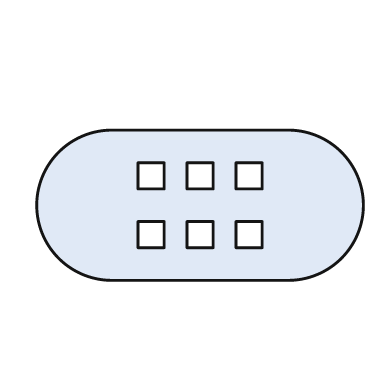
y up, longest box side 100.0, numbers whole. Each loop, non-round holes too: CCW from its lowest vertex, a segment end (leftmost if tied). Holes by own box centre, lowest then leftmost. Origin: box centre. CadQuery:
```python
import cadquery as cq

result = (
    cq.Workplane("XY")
    .moveTo(-27.0, -23.0)
    .lineTo(27.0, -23.0)
    .threePointArc((50.0, 0.0), (27.0, 23.0))
    .lineTo(-27.0, 23.0)
    .threePointArc((-50.0, 0.0), (-27.0, -23.0))
    .close()
    .moveTo(-19.0, -13.0)
    .lineTo(-11.0, -13.0)
    .lineTo(-11.0, -5.0)
    .lineTo(-19.0, -5.0)
    .close()
    .moveTo(-4.0, -13.0)
    .lineTo(4.0, -13.0)
    .lineTo(4.0, -5.0)
    .lineTo(-4.0, -5.0)
    .close()
    .moveTo(11.0, -13.0)
    .lineTo(19.0, -13.0)
    .lineTo(19.0, -5.0)
    .lineTo(11.0, -5.0)
    .close()
    .moveTo(-19.0, 5.0)
    .lineTo(-11.0, 5.0)
    .lineTo(-11.0, 13.0)
    .lineTo(-19.0, 13.0)
    .close()
    .moveTo(-4.0, 5.0)
    .lineTo(4.0, 5.0)
    .lineTo(4.0, 13.0)
    .lineTo(-4.0, 13.0)
    .close()
    .moveTo(11.0, 5.0)
    .lineTo(19.0, 5.0)
    .lineTo(19.0, 13.0)
    .lineTo(11.0, 13.0)
    .close()
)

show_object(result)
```